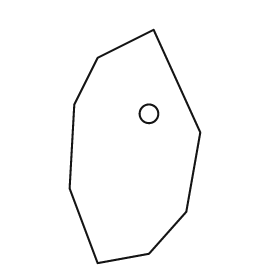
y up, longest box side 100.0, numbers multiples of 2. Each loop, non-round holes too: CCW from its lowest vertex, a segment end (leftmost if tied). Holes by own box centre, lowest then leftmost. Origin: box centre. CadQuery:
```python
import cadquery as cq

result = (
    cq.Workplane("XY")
    .moveTo(-16.0, -50.0)
    .lineTo(6.0, -46.0)
    .lineTo(22.0, -28.0)
    .lineTo(28.0, 6.0)
    .lineTo(8.0, 50.0)
    .lineTo(-16.0, 38.0)
    .lineTo(-26.0, 18.0)
    .lineTo(-28.0, -18.0)
    .close()
    .moveTo(6.0, 14.0)
    .circle(4.0)
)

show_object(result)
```